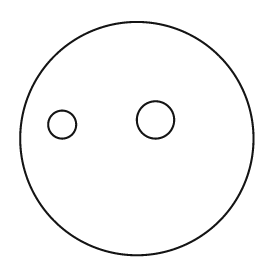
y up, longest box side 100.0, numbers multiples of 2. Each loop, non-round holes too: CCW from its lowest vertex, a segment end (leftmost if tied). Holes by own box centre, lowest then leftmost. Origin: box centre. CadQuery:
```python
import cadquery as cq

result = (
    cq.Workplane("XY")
    .moveTo(0.0, 0.0)
    .circle(50.0)
    .moveTo(-32.0, 6.0)
    .circle(6.0)
    .moveTo(8.0, 8.0)
    .circle(8.0)
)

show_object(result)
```